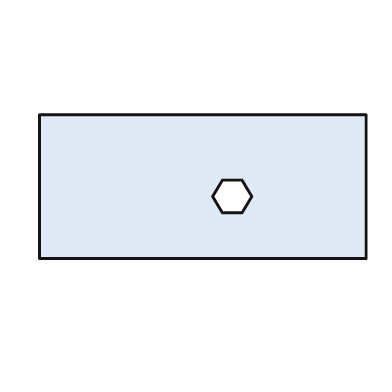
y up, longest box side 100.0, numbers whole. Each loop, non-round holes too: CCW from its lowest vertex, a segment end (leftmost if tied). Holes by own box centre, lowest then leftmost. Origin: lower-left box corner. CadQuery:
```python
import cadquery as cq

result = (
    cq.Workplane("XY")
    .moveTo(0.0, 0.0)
    .lineTo(100.0, 0.0)
    .lineTo(100.0, 44.0)
    .lineTo(0.0, 44.0)
    .close()
    .moveTo(56.0, 14.0)
    .lineTo(62.0, 14.0)
    .lineTo(65.0, 19.0)
    .lineTo(62.0, 24.0)
    .lineTo(56.0, 24.0)
    .lineTo(53.0, 19.0)
    .close()
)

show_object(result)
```